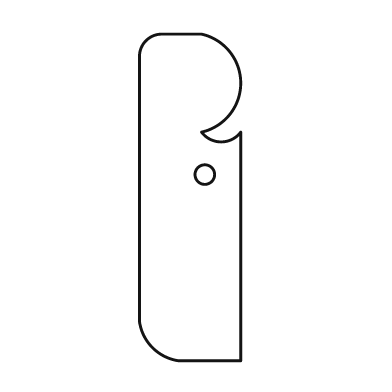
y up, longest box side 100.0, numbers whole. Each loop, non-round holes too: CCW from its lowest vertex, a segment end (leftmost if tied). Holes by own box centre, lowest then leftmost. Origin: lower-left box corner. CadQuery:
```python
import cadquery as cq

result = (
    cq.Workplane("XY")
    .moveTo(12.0, 0.0)
    .lineTo(31.0, 0.0)
    .lineTo(31.0, 70.0)
    .threePointArc((25.0, 67.0), (19.0, 70.0))
    .threePointArc((31.0, 85.0), (19.0, 100.0))
    .lineTo(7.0, 100.0)
    .threePointArc((2.0, 98.0), (0.0, 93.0))
    .lineTo(0.0, 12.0)
    .threePointArc((4.0, 4.0), (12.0, 0.0))
    .close()
    .moveTo(20.0, 57.0)
    .circle(3.0)
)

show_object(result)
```